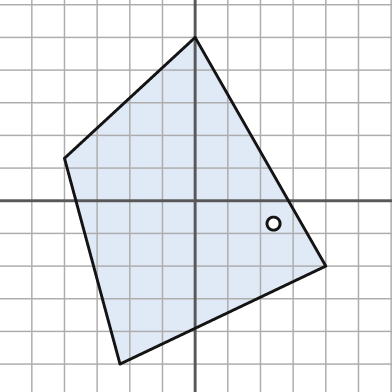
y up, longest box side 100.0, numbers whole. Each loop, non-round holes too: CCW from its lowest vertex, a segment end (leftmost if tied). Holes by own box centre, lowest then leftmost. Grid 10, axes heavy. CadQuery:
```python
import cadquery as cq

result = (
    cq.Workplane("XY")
    .moveTo(-23.0, -50.0)
    .lineTo(40.0, -20.0)
    .lineTo(0.0, 50.0)
    .lineTo(-40.0, 13.0)
    .close()
    .moveTo(24.0, -7.0)
    .circle(2.0)
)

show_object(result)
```